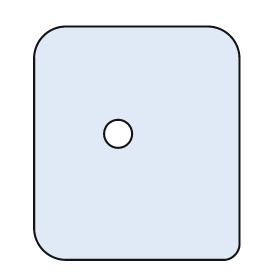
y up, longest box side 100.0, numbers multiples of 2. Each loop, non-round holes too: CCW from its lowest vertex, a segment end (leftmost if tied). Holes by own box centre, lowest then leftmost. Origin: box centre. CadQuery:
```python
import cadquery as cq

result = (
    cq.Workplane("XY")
    .moveTo(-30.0, -50.0)
    .lineTo(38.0, -50.0)
    .threePointArc((42.0, -48.0), (44.0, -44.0))
    .lineTo(44.0, 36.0)
    .threePointArc((40.0, 46.0), (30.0, 50.0))
    .lineTo(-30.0, 50.0)
    .threePointArc((-40.0, 46.0), (-44.0, 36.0))
    .lineTo(-44.0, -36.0)
    .threePointArc((-40.0, -46.0), (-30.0, -50.0))
    .close()
    .moveTo(-8.0, 4.0)
    .circle(6.0)
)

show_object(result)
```